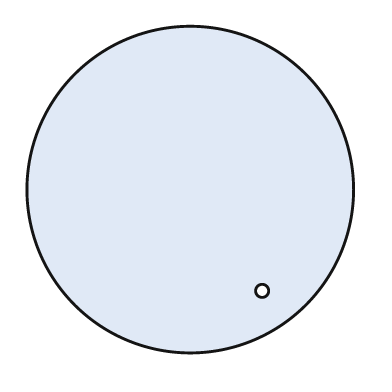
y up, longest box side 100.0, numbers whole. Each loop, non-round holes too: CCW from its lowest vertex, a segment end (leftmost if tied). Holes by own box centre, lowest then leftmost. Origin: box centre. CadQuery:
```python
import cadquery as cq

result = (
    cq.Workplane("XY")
    .moveTo(0.0, 0.0)
    .circle(50.0)
    .moveTo(22.0, -31.0)
    .circle(2.0)
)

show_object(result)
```